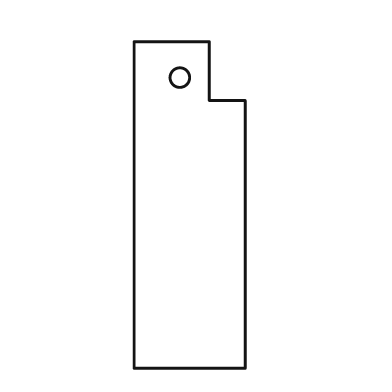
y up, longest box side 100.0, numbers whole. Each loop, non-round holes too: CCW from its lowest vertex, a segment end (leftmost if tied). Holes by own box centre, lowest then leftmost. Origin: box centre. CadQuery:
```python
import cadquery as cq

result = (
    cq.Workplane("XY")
    .moveTo(-17.0, -50.0)
    .lineTo(17.0, -50.0)
    .lineTo(17.0, 32.0)
    .lineTo(6.0, 32.0)
    .lineTo(6.0, 50.0)
    .lineTo(-17.0, 50.0)
    .close()
    .moveTo(-3.0, 39.0)
    .circle(3.0)
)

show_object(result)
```